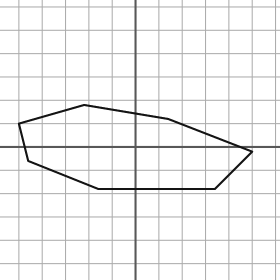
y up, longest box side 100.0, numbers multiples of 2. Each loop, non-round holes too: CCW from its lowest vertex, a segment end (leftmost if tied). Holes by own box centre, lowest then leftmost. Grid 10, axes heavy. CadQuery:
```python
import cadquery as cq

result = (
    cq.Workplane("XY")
    .moveTo(-16.0, -18.0)
    .lineTo(34.0, -18.0)
    .lineTo(50.0, -2.0)
    .lineTo(14.0, 12.0)
    .lineTo(-22.0, 18.0)
    .lineTo(-50.0, 10.0)
    .lineTo(-46.0, -6.0)
    .close()
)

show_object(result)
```